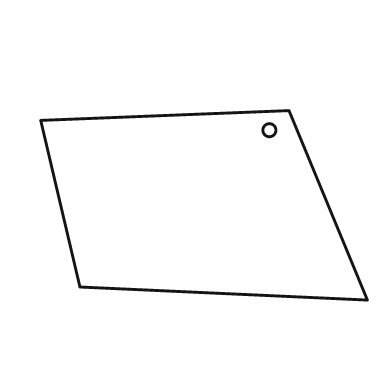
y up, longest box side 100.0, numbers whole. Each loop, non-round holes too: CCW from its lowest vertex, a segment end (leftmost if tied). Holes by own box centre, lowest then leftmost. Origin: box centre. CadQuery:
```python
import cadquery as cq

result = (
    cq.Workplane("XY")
    .moveTo(50.0, -29.0)
    .lineTo(26.0, 29.0)
    .lineTo(-50.0, 26.0)
    .lineTo(-38.0, -25.0)
    .close()
    .moveTo(20.0, 23.0)
    .circle(2.0)
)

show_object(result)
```